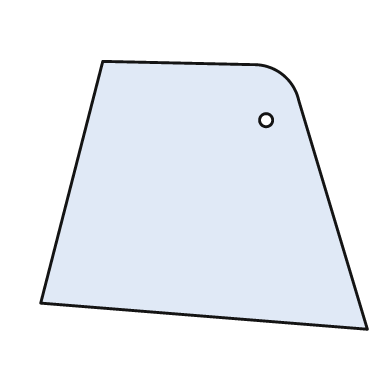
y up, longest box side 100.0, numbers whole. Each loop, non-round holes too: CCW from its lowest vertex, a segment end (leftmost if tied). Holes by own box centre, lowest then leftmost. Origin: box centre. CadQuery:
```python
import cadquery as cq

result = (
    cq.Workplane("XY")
    .moveTo(50.0, -41.0)
    .lineTo(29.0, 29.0)
    .threePointArc((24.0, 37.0), (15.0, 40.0))
    .lineTo(-31.0, 41.0)
    .lineTo(-50.0, -33.0)
    .close()
    .moveTo(19.0, 23.0)
    .circle(2.0)
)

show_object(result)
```